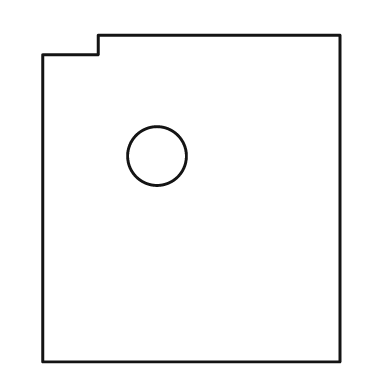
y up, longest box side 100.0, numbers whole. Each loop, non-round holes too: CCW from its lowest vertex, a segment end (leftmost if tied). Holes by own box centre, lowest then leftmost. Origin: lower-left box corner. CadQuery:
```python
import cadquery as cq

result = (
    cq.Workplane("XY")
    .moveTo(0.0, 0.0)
    .lineTo(91.0, 0.0)
    .lineTo(91.0, 100.0)
    .lineTo(17.0, 100.0)
    .lineTo(17.0, 94.0)
    .lineTo(0.0, 94.0)
    .close()
    .moveTo(35.0, 63.0)
    .circle(9.0)
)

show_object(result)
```